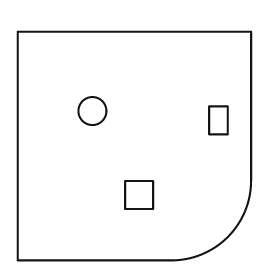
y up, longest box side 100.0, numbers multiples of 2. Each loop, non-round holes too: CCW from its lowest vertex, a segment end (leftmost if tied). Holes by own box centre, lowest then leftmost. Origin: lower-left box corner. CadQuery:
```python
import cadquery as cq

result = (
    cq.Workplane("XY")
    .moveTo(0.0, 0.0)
    .lineTo(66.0, 0.0)
    .threePointArc((90.0, 10.0), (100.0, 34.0))
    .lineTo(100.0, 98.0)
    .lineTo(0.0, 98.0)
    .close()
    .moveTo(46.0, 22.0)
    .lineTo(58.0, 22.0)
    .lineTo(58.0, 34.0)
    .lineTo(46.0, 34.0)
    .close()
    .moveTo(82.0, 54.0)
    .lineTo(90.0, 54.0)
    .lineTo(90.0, 66.0)
    .lineTo(82.0, 66.0)
    .close()
    .moveTo(32.0, 64.0)
    .circle(6.0)
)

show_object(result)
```